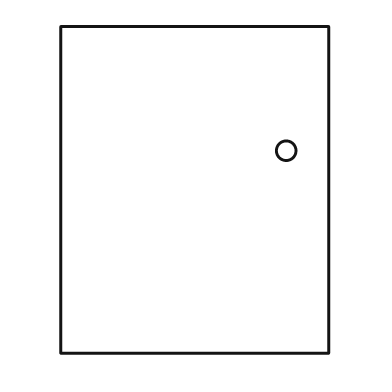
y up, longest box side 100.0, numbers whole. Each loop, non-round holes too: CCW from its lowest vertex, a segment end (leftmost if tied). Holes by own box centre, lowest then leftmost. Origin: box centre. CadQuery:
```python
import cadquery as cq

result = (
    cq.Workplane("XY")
    .moveTo(-41.0, -50.0)
    .lineTo(41.0, -50.0)
    .lineTo(41.0, 50.0)
    .lineTo(-41.0, 50.0)
    .close()
    .moveTo(28.0, 12.0)
    .circle(3.0)
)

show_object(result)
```